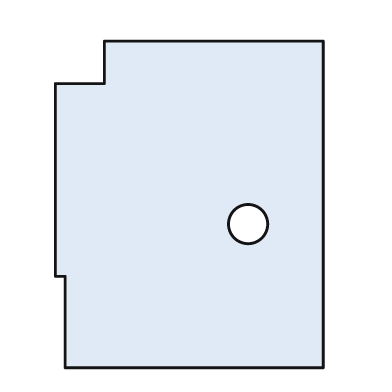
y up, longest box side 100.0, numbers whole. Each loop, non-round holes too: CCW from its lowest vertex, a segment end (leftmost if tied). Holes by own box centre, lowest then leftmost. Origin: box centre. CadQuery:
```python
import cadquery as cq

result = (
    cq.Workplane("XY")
    .moveTo(-38.0, -50.0)
    .lineTo(41.0, -50.0)
    .lineTo(41.0, 50.0)
    .lineTo(-26.0, 50.0)
    .lineTo(-26.0, 37.0)
    .lineTo(-41.0, 37.0)
    .lineTo(-41.0, -22.0)
    .lineTo(-38.0, -22.0)
    .close()
    .moveTo(18.0, -6.0)
    .circle(6.0)
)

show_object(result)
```